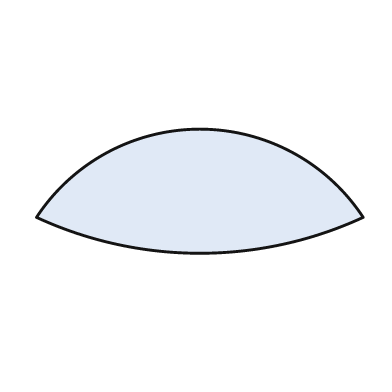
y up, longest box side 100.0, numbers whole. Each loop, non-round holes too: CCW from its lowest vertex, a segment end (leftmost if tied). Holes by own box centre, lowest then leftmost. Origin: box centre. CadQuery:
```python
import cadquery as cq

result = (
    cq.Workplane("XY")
    .moveTo(-50.0, -8.0)
    .threePointArc((0.0, -19.0), (50.0, -8.0))
    .threePointArc((0.0, 19.0), (-50.0, -8.0))
    .close()
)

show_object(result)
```